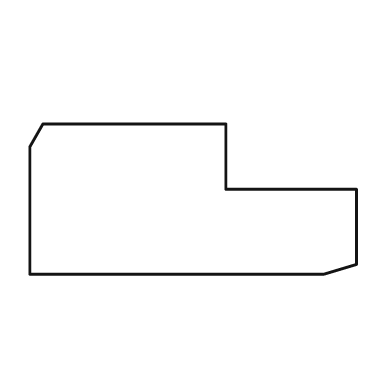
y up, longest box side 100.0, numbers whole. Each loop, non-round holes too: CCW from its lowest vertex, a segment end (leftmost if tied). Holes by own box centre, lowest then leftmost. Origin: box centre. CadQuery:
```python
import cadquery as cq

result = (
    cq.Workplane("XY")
    .moveTo(-50.0, -23.0)
    .lineTo(40.0, -23.0)
    .lineTo(50.0, -20.0)
    .lineTo(50.0, 3.0)
    .lineTo(10.0, 3.0)
    .lineTo(10.0, 23.0)
    .lineTo(-46.0, 23.0)
    .lineTo(-50.0, 16.0)
    .close()
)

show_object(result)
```